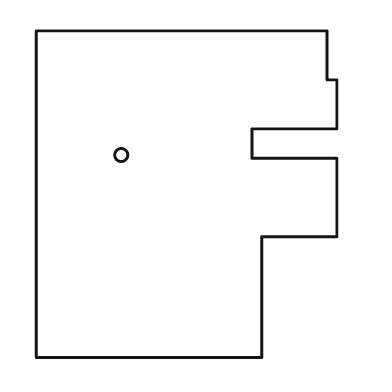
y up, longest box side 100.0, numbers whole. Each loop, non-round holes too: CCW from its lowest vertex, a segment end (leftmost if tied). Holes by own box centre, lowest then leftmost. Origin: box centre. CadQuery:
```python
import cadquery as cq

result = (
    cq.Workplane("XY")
    .moveTo(-46.0, -50.0)
    .lineTo(23.0, -50.0)
    .lineTo(23.0, -13.0)
    .lineTo(46.0, -13.0)
    .lineTo(46.0, 11.0)
    .lineTo(20.0, 11.0)
    .lineTo(20.0, 20.0)
    .lineTo(46.0, 20.0)
    .lineTo(46.0, 35.0)
    .lineTo(43.0, 35.0)
    .lineTo(43.0, 50.0)
    .lineTo(-46.0, 50.0)
    .close()
    .moveTo(-20.0, 12.0)
    .circle(2.0)
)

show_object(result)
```